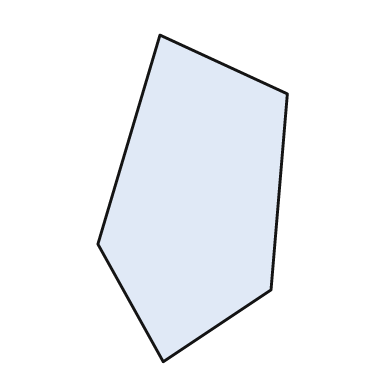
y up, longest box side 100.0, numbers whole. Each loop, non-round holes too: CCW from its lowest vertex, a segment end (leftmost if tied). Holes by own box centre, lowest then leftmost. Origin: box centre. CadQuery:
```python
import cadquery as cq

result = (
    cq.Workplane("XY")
    .moveTo(-9.0, -50.0)
    .lineTo(24.0, -28.0)
    .lineTo(29.0, 32.0)
    .lineTo(-10.0, 50.0)
    .lineTo(-29.0, -14.0)
    .close()
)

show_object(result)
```